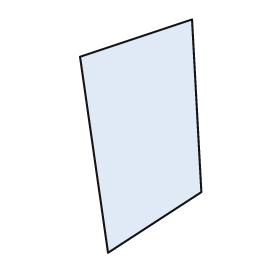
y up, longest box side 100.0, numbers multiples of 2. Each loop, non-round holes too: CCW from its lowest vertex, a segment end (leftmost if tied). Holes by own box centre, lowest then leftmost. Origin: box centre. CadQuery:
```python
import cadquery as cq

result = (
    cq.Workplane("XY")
    .moveTo(-14.0, -50.0)
    .lineTo(26.0, -24.0)
    .lineTo(22.0, 50.0)
    .lineTo(-26.0, 34.0)
    .close()
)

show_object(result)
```